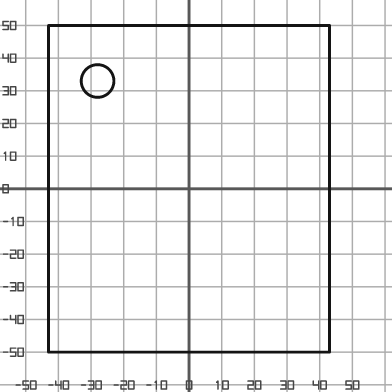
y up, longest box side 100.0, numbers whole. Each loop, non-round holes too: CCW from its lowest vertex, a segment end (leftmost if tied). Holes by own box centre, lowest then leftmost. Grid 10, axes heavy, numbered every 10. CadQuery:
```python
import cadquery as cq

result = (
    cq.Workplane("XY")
    .moveTo(-43.0, -50.0)
    .lineTo(43.0, -50.0)
    .lineTo(43.0, 50.0)
    .lineTo(-43.0, 50.0)
    .close()
    .moveTo(-28.0, 33.0)
    .circle(5.0)
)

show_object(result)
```